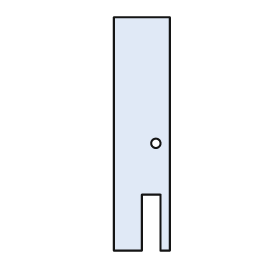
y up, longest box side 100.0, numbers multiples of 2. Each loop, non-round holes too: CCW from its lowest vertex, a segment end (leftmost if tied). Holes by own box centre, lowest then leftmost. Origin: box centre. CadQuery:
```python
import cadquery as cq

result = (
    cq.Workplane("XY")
    .moveTo(-12.0, -50.0)
    .lineTo(0.0, -50.0)
    .lineTo(0.0, -26.0)
    .lineTo(8.0, -26.0)
    .lineTo(8.0, -50.0)
    .lineTo(12.0, -50.0)
    .lineTo(12.0, 50.0)
    .lineTo(-12.0, 50.0)
    .close()
    .moveTo(6.0, -4.0)
    .circle(2.0)
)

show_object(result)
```